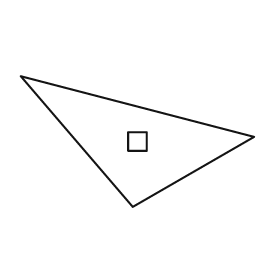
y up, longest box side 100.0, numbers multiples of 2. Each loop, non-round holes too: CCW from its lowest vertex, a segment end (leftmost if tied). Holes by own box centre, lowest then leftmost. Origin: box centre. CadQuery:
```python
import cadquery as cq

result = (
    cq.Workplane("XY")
    .moveTo(-2.0, -28.0)
    .lineTo(50.0, 2.0)
    .lineTo(-50.0, 28.0)
    .close()
    .moveTo(-4.0, -4.0)
    .lineTo(4.0, -4.0)
    .lineTo(4.0, 4.0)
    .lineTo(-4.0, 4.0)
    .close()
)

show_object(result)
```